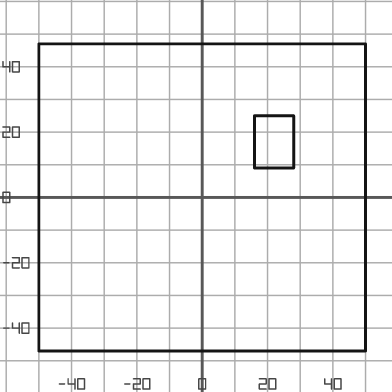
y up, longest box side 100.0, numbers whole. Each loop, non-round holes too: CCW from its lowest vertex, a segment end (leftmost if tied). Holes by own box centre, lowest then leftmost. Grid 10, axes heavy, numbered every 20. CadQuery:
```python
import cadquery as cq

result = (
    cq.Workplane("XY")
    .moveTo(-50.0, -47.0)
    .lineTo(50.0, -47.0)
    .lineTo(50.0, 47.0)
    .lineTo(-50.0, 47.0)
    .close()
    .moveTo(16.0, 9.0)
    .lineTo(28.0, 9.0)
    .lineTo(28.0, 25.0)
    .lineTo(16.0, 25.0)
    .close()
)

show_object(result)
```